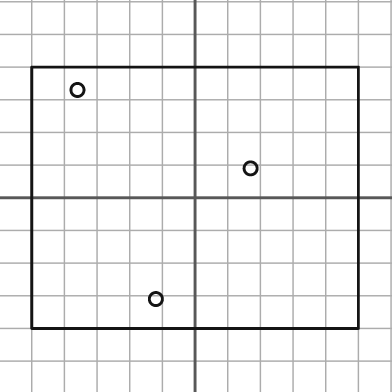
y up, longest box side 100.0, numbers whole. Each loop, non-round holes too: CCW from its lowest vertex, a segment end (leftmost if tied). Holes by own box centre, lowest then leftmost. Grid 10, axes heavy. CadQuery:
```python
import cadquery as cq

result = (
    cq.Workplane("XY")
    .moveTo(-50.0, -40.0)
    .lineTo(50.0, -40.0)
    .lineTo(50.0, 40.0)
    .lineTo(-50.0, 40.0)
    .close()
    .moveTo(-12.0, -31.0)
    .circle(2.0)
    .moveTo(17.0, 9.0)
    .circle(2.0)
    .moveTo(-36.0, 33.0)
    .circle(2.0)
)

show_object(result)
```